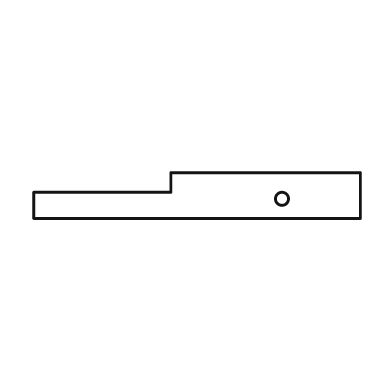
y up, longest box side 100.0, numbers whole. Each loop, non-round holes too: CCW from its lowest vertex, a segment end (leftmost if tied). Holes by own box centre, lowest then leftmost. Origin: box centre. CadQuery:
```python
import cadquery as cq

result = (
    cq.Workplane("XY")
    .moveTo(-50.0, -7.0)
    .lineTo(50.0, -7.0)
    .lineTo(50.0, 7.0)
    .lineTo(-8.0, 7.0)
    .lineTo(-8.0, 1.0)
    .lineTo(-50.0, 1.0)
    .close()
    .moveTo(26.0, -1.0)
    .circle(2.0)
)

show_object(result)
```